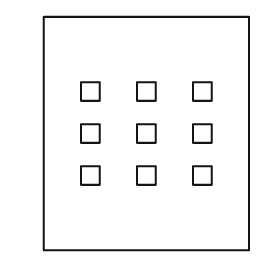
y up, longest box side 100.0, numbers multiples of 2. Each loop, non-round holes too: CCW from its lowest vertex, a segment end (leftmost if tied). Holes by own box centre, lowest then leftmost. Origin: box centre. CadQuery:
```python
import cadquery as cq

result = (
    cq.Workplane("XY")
    .moveTo(-44.0, -50.0)
    .lineTo(44.0, -50.0)
    .lineTo(44.0, 50.0)
    .lineTo(-44.0, 50.0)
    .close()
    .moveTo(-28.0, -22.0)
    .lineTo(-20.0, -22.0)
    .lineTo(-20.0, -14.0)
    .lineTo(-28.0, -14.0)
    .close()
    .moveTo(-4.0, -22.0)
    .lineTo(4.0, -22.0)
    .lineTo(4.0, -14.0)
    .lineTo(-4.0, -14.0)
    .close()
    .moveTo(20.0, -22.0)
    .lineTo(28.0, -22.0)
    .lineTo(28.0, -14.0)
    .lineTo(20.0, -14.0)
    .close()
    .moveTo(-28.0, -4.0)
    .lineTo(-20.0, -4.0)
    .lineTo(-20.0, 4.0)
    .lineTo(-28.0, 4.0)
    .close()
    .moveTo(-4.0, -4.0)
    .lineTo(4.0, -4.0)
    .lineTo(4.0, 4.0)
    .lineTo(-4.0, 4.0)
    .close()
    .moveTo(20.0, -4.0)
    .lineTo(28.0, -4.0)
    .lineTo(28.0, 4.0)
    .lineTo(20.0, 4.0)
    .close()
    .moveTo(-28.0, 14.0)
    .lineTo(-20.0, 14.0)
    .lineTo(-20.0, 22.0)
    .lineTo(-28.0, 22.0)
    .close()
    .moveTo(-4.0, 14.0)
    .lineTo(4.0, 14.0)
    .lineTo(4.0, 22.0)
    .lineTo(-4.0, 22.0)
    .close()
    .moveTo(20.0, 14.0)
    .lineTo(28.0, 14.0)
    .lineTo(28.0, 22.0)
    .lineTo(20.0, 22.0)
    .close()
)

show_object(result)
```